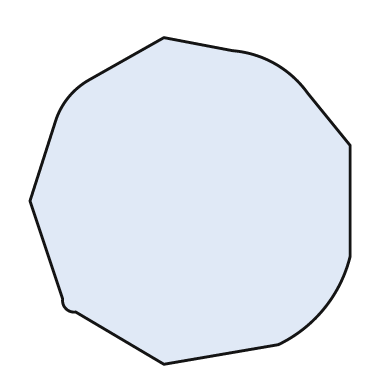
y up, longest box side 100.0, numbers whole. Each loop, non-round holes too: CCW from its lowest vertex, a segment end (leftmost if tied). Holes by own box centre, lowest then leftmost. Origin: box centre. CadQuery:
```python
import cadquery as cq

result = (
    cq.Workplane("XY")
    .moveTo(-8.0, -50.0)
    .lineTo(27.0, -44.0)
    .threePointArc((41.0, -33.0), (49.0, -17.0))
    .lineTo(49.0, 17.0)
    .lineTo(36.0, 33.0)
    .threePointArc((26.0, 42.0), (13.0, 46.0))
    .lineTo(-8.0, 50.0)
    .lineTo(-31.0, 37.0)
    .threePointArc((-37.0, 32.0), (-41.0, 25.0))
    .lineTo(-49.0, 0.0)
    .lineTo(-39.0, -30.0)
    .threePointArc((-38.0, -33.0), (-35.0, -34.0))
    .close()
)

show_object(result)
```